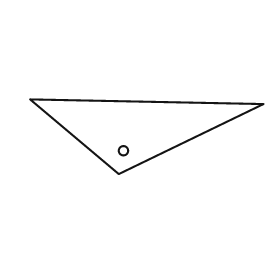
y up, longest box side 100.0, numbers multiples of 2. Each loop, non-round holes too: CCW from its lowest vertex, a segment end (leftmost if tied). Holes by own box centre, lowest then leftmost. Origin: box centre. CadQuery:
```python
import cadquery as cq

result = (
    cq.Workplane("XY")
    .moveTo(-12.0, -16.0)
    .lineTo(50.0, 14.0)
    .lineTo(-50.0, 16.0)
    .close()
    .moveTo(-10.0, -6.0)
    .circle(2.0)
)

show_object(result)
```